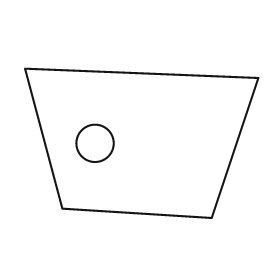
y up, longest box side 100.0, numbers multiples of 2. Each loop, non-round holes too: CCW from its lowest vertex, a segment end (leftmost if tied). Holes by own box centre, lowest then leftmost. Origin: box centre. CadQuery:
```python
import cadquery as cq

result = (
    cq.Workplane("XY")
    .moveTo(30.0, -32.0)
    .lineTo(50.0, 28.0)
    .lineTo(-50.0, 32.0)
    .lineTo(-34.0, -28.0)
    .close()
    .moveTo(-20.0, 0.0)
    .circle(8.0)
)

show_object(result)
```